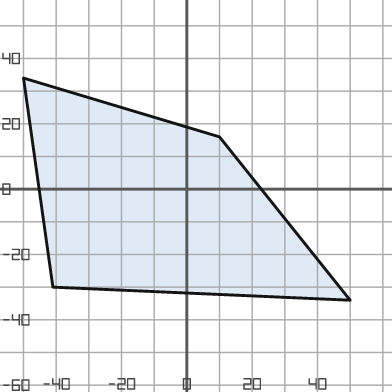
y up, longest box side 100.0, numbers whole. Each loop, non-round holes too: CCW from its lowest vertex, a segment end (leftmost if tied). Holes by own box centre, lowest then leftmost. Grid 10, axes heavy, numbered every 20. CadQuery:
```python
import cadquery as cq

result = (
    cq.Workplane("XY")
    .moveTo(50.0, -34.0)
    .lineTo(10.0, 16.0)
    .lineTo(-50.0, 34.0)
    .lineTo(-41.0, -30.0)
    .close()
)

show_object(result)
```